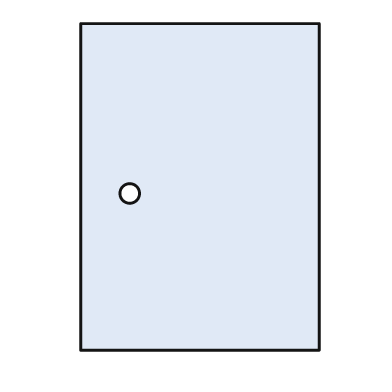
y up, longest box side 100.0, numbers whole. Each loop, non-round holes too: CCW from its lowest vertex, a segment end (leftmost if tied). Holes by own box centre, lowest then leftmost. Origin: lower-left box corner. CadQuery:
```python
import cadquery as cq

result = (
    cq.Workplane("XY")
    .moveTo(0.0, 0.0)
    .lineTo(73.0, 0.0)
    .lineTo(73.0, 100.0)
    .lineTo(0.0, 100.0)
    .close()
    .moveTo(15.0, 48.0)
    .circle(3.0)
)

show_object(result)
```